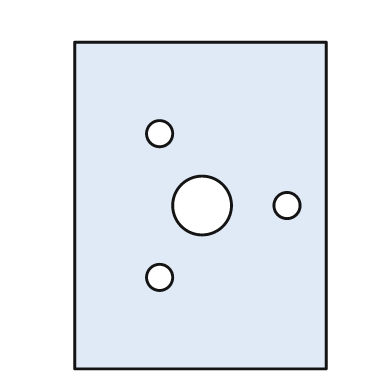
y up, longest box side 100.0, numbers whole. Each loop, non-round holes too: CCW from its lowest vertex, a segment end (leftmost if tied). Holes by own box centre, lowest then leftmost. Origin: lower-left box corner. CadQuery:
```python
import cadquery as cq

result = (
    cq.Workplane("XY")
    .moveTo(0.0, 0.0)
    .lineTo(77.0, 0.0)
    .lineTo(77.0, 100.0)
    .lineTo(0.0, 100.0)
    .close()
    .moveTo(26.0, 28.0)
    .circle(4.0)
    .moveTo(39.0, 50.0)
    .circle(9.0)
    .moveTo(65.0, 50.0)
    .circle(4.0)
    .moveTo(26.0, 72.0)
    .circle(4.0)
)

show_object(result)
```